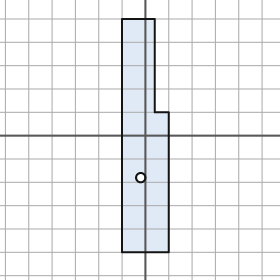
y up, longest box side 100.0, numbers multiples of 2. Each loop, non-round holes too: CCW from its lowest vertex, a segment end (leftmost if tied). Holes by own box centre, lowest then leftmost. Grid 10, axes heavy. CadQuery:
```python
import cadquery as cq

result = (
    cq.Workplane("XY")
    .moveTo(-10.0, -50.0)
    .lineTo(10.0, -50.0)
    .lineTo(10.0, 10.0)
    .lineTo(4.0, 10.0)
    .lineTo(4.0, 50.0)
    .lineTo(-10.0, 50.0)
    .close()
    .moveTo(-2.0, -18.0)
    .circle(2.0)
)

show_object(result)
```